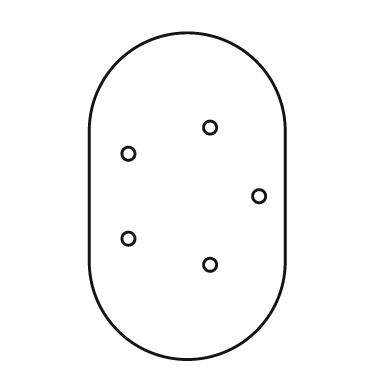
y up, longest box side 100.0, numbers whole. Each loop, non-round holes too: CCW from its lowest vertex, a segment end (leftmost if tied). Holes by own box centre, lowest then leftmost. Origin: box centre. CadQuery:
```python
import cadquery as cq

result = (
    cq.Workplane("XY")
    .moveTo(-30.0, -20.0)
    .threePointArc((0.0, -50.0), (30.0, -20.0))
    .lineTo(30.0, 20.0)
    .threePointArc((0.0, 50.0), (-30.0, 20.0))
    .close()
    .moveTo(7.0, -21.0)
    .circle(2.0)
    .moveTo(-18.0, -13.0)
    .circle(2.0)
    .moveTo(22.0, 0.0)
    .circle(2.0)
    .moveTo(-18.0, 13.0)
    .circle(2.0)
    .moveTo(7.0, 21.0)
    .circle(2.0)
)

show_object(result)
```